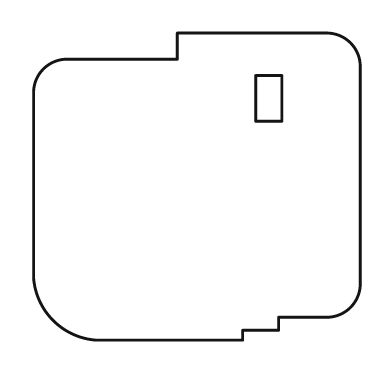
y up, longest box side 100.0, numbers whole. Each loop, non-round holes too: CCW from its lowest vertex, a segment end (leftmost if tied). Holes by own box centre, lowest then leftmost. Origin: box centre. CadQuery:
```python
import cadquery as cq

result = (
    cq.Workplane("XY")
    .moveTo(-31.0, -47.0)
    .lineTo(14.0, -47.0)
    .lineTo(14.0, -44.0)
    .lineTo(25.0, -44.0)
    .lineTo(25.0, -40.0)
    .lineTo(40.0, -40.0)
    .threePointArc((47.0, -37.0), (50.0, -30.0))
    .lineTo(50.0, 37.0)
    .threePointArc((47.0, 44.0), (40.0, 47.0))
    .lineTo(-6.0, 47.0)
    .lineTo(-6.0, 39.0)
    .lineTo(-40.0, 39.0)
    .threePointArc((-47.0, 36.0), (-50.0, 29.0))
    .lineTo(-50.0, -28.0)
    .threePointArc((-44.0, -41.0), (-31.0, -47.0))
    .close()
    .moveTo(18.0, 20.0)
    .lineTo(26.0, 20.0)
    .lineTo(26.0, 34.0)
    .lineTo(18.0, 34.0)
    .close()
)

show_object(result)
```